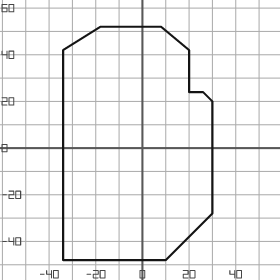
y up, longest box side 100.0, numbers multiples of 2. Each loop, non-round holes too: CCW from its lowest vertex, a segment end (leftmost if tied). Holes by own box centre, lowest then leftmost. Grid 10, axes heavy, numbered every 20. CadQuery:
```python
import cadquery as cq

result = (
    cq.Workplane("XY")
    .moveTo(-34.0, -48.0)
    .lineTo(10.0, -48.0)
    .lineTo(30.0, -28.0)
    .lineTo(30.0, 20.0)
    .lineTo(26.0, 24.0)
    .lineTo(20.0, 24.0)
    .lineTo(20.0, 42.0)
    .lineTo(8.0, 52.0)
    .lineTo(-18.0, 52.0)
    .lineTo(-34.0, 42.0)
    .close()
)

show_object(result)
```